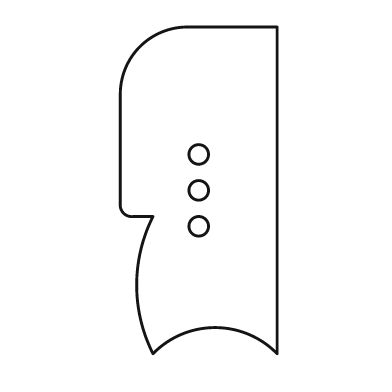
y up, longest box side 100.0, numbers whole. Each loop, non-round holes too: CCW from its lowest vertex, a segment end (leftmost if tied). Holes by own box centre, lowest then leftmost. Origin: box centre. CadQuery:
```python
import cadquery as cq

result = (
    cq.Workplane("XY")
    .moveTo(-14.0, -50.0)
    .threePointArc((5.0, -42.0), (24.0, -50.0))
    .lineTo(24.0, 50.0)
    .lineTo(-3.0, 50.0)
    .threePointArc((-18.0, 44.0), (-24.0, 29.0))
    .lineTo(-24.0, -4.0)
    .threePointArc((-23.0, -7.0), (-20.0, -8.0))
    .lineTo(-14.0, -8.0)
    .threePointArc((-19.0, -29.0), (-14.0, -50.0))
    .close()
    .moveTo(0.0, -11.0)
    .circle(3.0)
    .moveTo(0.0, 0.0)
    .circle(3.0)
    .moveTo(0.0, 11.0)
    .circle(3.0)
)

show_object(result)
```